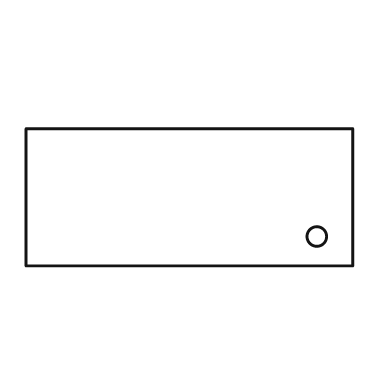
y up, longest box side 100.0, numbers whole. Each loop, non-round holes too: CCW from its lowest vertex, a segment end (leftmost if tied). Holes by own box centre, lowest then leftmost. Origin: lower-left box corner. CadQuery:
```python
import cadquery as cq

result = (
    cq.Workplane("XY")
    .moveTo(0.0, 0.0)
    .lineTo(100.0, 0.0)
    .lineTo(100.0, 42.0)
    .lineTo(0.0, 42.0)
    .close()
    .moveTo(89.0, 9.0)
    .circle(3.0)
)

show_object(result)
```